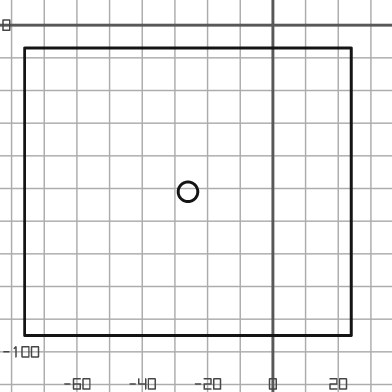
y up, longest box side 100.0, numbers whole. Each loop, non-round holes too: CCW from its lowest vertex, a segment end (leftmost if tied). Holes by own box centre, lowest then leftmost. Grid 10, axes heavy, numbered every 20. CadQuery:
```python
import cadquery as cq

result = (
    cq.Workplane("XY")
    .moveTo(-76.0, -95.0)
    .lineTo(24.0, -95.0)
    .lineTo(24.0, -7.0)
    .lineTo(-76.0, -7.0)
    .close()
    .moveTo(-26.0, -51.0)
    .circle(3.0)
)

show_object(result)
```